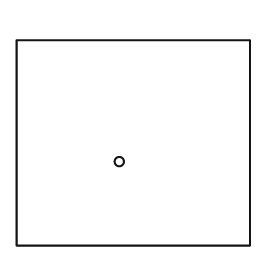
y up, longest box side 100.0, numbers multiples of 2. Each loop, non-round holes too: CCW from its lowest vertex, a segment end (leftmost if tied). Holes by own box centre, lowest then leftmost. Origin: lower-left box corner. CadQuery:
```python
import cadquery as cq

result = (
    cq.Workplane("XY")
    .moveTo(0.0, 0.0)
    .lineTo(100.0, 0.0)
    .lineTo(100.0, 88.0)
    .lineTo(0.0, 88.0)
    .close()
    .moveTo(44.0, 36.0)
    .circle(2.0)
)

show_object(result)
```